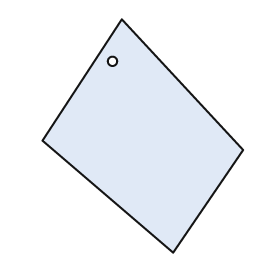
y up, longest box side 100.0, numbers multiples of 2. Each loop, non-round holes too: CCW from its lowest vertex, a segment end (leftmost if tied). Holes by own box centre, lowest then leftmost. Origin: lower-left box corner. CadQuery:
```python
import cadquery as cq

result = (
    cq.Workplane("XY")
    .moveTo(56.0, 0.0)
    .lineTo(86.0, 44.0)
    .lineTo(34.0, 100.0)
    .lineTo(0.0, 48.0)
    .close()
    .moveTo(30.0, 82.0)
    .circle(2.0)
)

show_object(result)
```